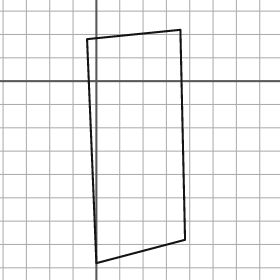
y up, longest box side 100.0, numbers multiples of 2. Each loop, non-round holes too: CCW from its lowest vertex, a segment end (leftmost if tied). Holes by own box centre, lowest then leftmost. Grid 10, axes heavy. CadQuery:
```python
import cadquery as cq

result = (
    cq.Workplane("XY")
    .moveTo(0.0, -78.0)
    .lineTo(38.0, -68.0)
    .lineTo(36.0, 22.0)
    .lineTo(-4.0, 18.0)
    .close()
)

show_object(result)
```